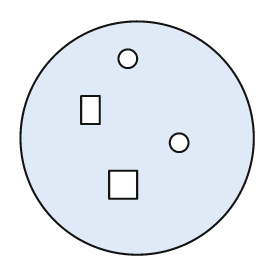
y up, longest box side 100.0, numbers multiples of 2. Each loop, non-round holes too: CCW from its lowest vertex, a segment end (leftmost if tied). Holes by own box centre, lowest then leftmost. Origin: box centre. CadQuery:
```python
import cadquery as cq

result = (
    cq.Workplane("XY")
    .moveTo(0.0, 0.0)
    .circle(50.0)
    .moveTo(-12.0, -26.0)
    .lineTo(0.0, -26.0)
    .lineTo(0.0, -14.0)
    .lineTo(-12.0, -14.0)
    .close()
    .moveTo(18.0, -2.0)
    .circle(4.0)
    .moveTo(-24.0, 6.0)
    .lineTo(-16.0, 6.0)
    .lineTo(-16.0, 18.0)
    .lineTo(-24.0, 18.0)
    .close()
    .moveTo(-4.0, 34.0)
    .circle(4.0)
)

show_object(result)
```